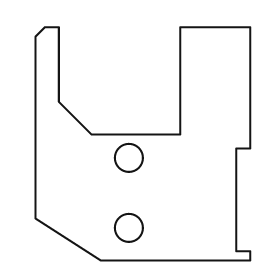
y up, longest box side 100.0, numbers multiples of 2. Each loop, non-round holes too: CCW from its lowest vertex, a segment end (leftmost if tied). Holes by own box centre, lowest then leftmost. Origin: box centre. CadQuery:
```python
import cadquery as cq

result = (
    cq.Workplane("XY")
    .moveTo(-18.0, -50.0)
    .lineTo(46.0, -50.0)
    .lineTo(46.0, -46.0)
    .lineTo(40.0, -46.0)
    .lineTo(40.0, -2.0)
    .lineTo(46.0, -2.0)
    .lineTo(46.0, 50.0)
    .lineTo(16.0, 50.0)
    .lineTo(16.0, 4.0)
    .lineTo(-22.0, 4.0)
    .lineTo(-36.0, 18.0)
    .lineTo(-36.0, 50.0)
    .lineTo(-42.0, 50.0)
    .lineTo(-46.0, 46.0)
    .lineTo(-46.0, -32.0)
    .close()
    .moveTo(-6.0, -36.0)
    .circle(6.0)
    .moveTo(-6.0, -6.0)
    .circle(6.0)
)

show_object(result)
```